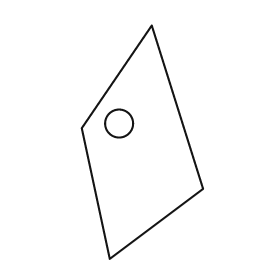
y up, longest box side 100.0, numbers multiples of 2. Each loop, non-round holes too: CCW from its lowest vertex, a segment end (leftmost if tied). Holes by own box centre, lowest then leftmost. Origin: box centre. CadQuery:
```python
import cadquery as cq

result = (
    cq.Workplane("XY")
    .moveTo(-14.0, -50.0)
    .lineTo(26.0, -20.0)
    .lineTo(4.0, 50.0)
    .lineTo(-26.0, 6.0)
    .close()
    .moveTo(-10.0, 8.0)
    .circle(6.0)
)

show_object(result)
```